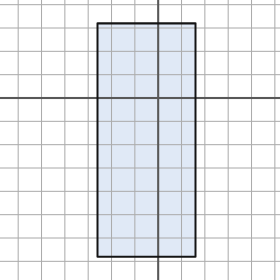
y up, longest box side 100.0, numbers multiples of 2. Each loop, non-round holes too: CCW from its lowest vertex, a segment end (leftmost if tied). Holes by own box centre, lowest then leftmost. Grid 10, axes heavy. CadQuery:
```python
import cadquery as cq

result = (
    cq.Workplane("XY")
    .moveTo(-26.0, -68.0)
    .lineTo(16.0, -68.0)
    .lineTo(16.0, 32.0)
    .lineTo(-26.0, 32.0)
    .close()
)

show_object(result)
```